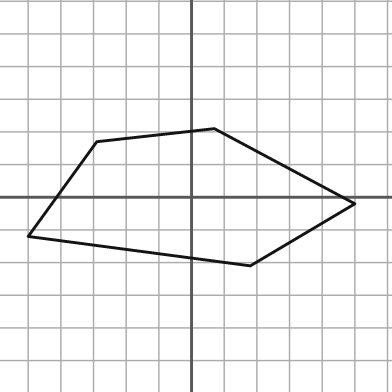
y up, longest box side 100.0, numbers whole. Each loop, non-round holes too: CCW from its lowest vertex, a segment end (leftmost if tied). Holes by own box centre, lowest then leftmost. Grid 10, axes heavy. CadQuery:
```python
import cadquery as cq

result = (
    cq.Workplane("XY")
    .moveTo(18.0, -21.0)
    .lineTo(50.0, -2.0)
    .lineTo(7.0, 21.0)
    .lineTo(-29.0, 17.0)
    .lineTo(-50.0, -12.0)
    .close()
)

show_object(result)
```